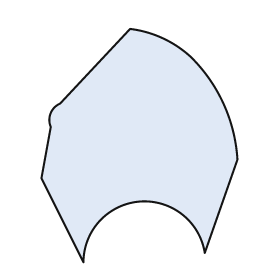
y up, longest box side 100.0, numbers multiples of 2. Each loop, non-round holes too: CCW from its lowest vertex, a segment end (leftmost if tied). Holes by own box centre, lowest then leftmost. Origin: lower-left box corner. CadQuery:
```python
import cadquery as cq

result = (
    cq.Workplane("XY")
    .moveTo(18.0, 0.0)
    .threePointArc((42.0, 26.0), (70.0, 4.0))
    .lineTo(84.0, 44.0)
    .threePointArc((78.0, 68.0), (64.0, 88.0))
    .threePointArc((52.0, 96.0), (38.0, 100.0))
    .lineTo(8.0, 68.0)
    .threePointArc((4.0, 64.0), (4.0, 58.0))
    .lineTo(0.0, 36.0)
    .close()
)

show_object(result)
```